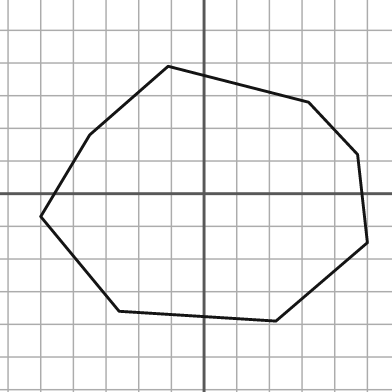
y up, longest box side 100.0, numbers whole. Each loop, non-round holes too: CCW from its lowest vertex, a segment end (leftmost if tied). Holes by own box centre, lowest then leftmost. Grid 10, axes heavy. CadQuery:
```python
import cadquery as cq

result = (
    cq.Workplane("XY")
    .moveTo(22.0, -39.0)
    .lineTo(50.0, -15.0)
    .lineTo(47.0, 12.0)
    .lineTo(32.0, 28.0)
    .lineTo(-11.0, 39.0)
    .lineTo(-35.0, 18.0)
    .lineTo(-50.0, -7.0)
    .lineTo(-26.0, -36.0)
    .close()
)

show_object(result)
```